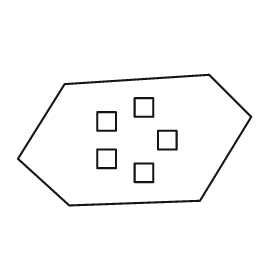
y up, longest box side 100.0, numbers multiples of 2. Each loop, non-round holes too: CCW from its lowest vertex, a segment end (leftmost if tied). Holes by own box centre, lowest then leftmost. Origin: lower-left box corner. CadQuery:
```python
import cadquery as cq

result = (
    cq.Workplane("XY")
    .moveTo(22.0, 0.0)
    .lineTo(78.0, 2.0)
    .lineTo(100.0, 38.0)
    .lineTo(82.0, 56.0)
    .lineTo(20.0, 52.0)
    .lineTo(0.0, 20.0)
    .close()
    .moveTo(50.0, 10.0)
    .lineTo(58.0, 10.0)
    .lineTo(58.0, 18.0)
    .lineTo(50.0, 18.0)
    .close()
    .moveTo(34.0, 16.0)
    .lineTo(42.0, 16.0)
    .lineTo(42.0, 24.0)
    .lineTo(34.0, 24.0)
    .close()
    .moveTo(60.0, 24.0)
    .lineTo(68.0, 24.0)
    .lineTo(68.0, 32.0)
    .lineTo(60.0, 32.0)
    .close()
    .moveTo(34.0, 32.0)
    .lineTo(42.0, 32.0)
    .lineTo(42.0, 40.0)
    .lineTo(34.0, 40.0)
    .close()
    .moveTo(50.0, 38.0)
    .lineTo(58.0, 38.0)
    .lineTo(58.0, 46.0)
    .lineTo(50.0, 46.0)
    .close()
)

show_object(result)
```